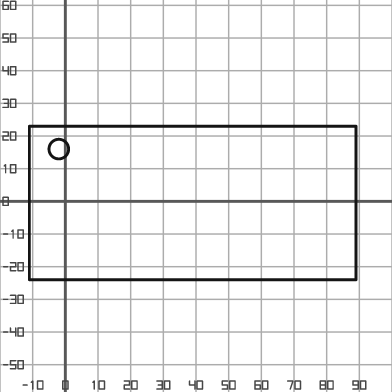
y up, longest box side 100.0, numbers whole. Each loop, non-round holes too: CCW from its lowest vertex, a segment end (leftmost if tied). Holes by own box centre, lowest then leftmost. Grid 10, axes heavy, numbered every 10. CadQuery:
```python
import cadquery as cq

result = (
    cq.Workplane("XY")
    .moveTo(-11.0, -24.0)
    .lineTo(89.0, -24.0)
    .lineTo(89.0, 23.0)
    .lineTo(-11.0, 23.0)
    .close()
    .moveTo(-2.0, 16.0)
    .circle(3.0)
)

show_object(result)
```